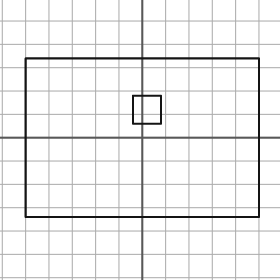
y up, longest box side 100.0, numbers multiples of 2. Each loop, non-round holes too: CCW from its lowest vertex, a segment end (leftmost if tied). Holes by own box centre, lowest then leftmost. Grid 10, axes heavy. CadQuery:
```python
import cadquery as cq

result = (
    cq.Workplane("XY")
    .moveTo(-50.0, -34.0)
    .lineTo(50.0, -34.0)
    .lineTo(50.0, 34.0)
    .lineTo(-50.0, 34.0)
    .close()
    .moveTo(-4.0, 6.0)
    .lineTo(8.0, 6.0)
    .lineTo(8.0, 18.0)
    .lineTo(-4.0, 18.0)
    .close()
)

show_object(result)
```